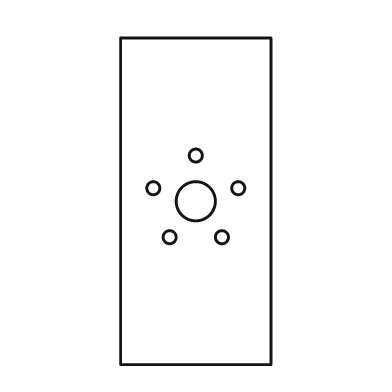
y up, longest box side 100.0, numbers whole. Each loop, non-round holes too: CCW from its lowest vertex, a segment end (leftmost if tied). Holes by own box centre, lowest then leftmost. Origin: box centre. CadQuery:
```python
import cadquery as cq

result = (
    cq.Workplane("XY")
    .moveTo(-23.0, -50.0)
    .lineTo(23.0, -50.0)
    .lineTo(23.0, 50.0)
    .lineTo(-23.0, 50.0)
    .close()
    .moveTo(-8.0, -11.0)
    .circle(2.0)
    .moveTo(8.0, -11.0)
    .circle(2.0)
    .moveTo(0.0, 0.0)
    .circle(6.0)
    .moveTo(-13.0, 4.0)
    .circle(2.0)
    .moveTo(13.0, 4.0)
    .circle(2.0)
    .moveTo(0.0, 14.0)
    .circle(2.0)
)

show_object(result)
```